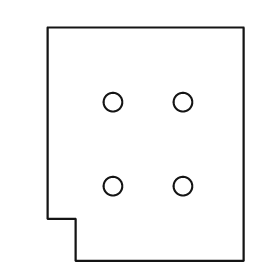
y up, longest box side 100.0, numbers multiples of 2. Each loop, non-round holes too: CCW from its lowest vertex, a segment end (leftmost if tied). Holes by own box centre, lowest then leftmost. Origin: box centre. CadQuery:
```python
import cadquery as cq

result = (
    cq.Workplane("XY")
    .moveTo(-30.0, -50.0)
    .lineTo(42.0, -50.0)
    .lineTo(42.0, 50.0)
    .lineTo(-42.0, 50.0)
    .lineTo(-42.0, -32.0)
    .lineTo(-30.0, -32.0)
    .close()
    .moveTo(-14.0, -18.0)
    .circle(4.0)
    .moveTo(16.0, -18.0)
    .circle(4.0)
    .moveTo(-14.0, 18.0)
    .circle(4.0)
    .moveTo(16.0, 18.0)
    .circle(4.0)
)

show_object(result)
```